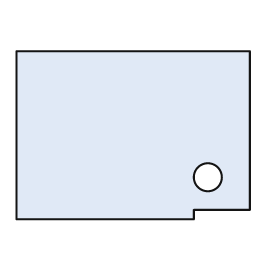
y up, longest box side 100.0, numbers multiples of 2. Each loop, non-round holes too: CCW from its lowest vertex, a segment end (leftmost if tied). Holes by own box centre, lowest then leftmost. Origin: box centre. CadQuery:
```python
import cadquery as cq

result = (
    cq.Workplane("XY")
    .moveTo(-50.0, -36.0)
    .lineTo(26.0, -36.0)
    .lineTo(26.0, -32.0)
    .lineTo(50.0, -32.0)
    .lineTo(50.0, 36.0)
    .lineTo(-50.0, 36.0)
    .close()
    .moveTo(32.0, -18.0)
    .circle(6.0)
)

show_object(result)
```